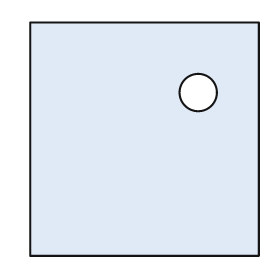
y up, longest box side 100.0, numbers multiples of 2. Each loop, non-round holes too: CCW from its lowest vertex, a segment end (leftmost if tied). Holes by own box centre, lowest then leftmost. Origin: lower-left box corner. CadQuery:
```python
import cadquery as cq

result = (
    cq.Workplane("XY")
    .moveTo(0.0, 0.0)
    .lineTo(98.0, 0.0)
    .lineTo(98.0, 100.0)
    .lineTo(0.0, 100.0)
    .close()
    .moveTo(72.0, 70.0)
    .circle(8.0)
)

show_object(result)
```